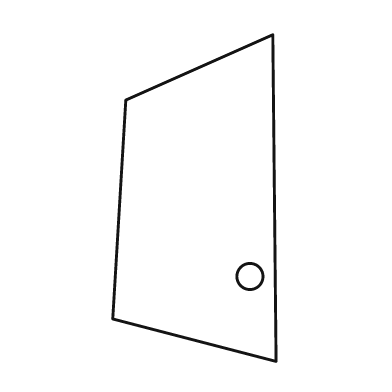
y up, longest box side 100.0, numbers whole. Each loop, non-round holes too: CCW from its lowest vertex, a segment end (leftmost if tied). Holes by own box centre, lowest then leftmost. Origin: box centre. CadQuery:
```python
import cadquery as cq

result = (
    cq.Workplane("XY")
    .moveTo(25.0, -50.0)
    .lineTo(24.0, 50.0)
    .lineTo(-21.0, 30.0)
    .lineTo(-25.0, -37.0)
    .close()
    .moveTo(17.0, -24.0)
    .circle(4.0)
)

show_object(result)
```